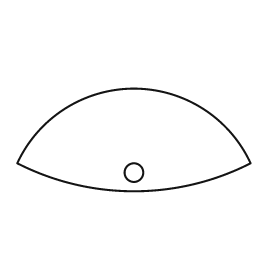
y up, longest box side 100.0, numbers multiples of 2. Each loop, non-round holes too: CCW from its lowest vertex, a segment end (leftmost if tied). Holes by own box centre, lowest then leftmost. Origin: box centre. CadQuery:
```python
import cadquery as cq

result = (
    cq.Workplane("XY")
    .moveTo(-50.0, -10.0)
    .threePointArc((0.0, -22.0), (50.0, -10.0))
    .threePointArc((0.0, 22.0), (-50.0, -10.0))
    .close()
    .moveTo(0.0, -14.0)
    .circle(4.0)
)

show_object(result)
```